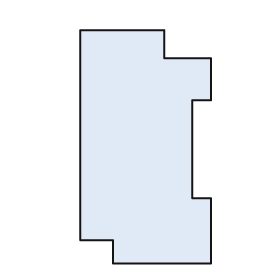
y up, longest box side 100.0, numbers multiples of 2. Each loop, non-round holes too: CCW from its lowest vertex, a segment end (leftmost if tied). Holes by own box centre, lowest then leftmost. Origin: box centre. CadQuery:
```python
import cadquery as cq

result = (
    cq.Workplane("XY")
    .moveTo(-14.0, -50.0)
    .lineTo(28.0, -50.0)
    .lineTo(28.0, -22.0)
    .lineTo(20.0, -22.0)
    .lineTo(20.0, 20.0)
    .lineTo(28.0, 20.0)
    .lineTo(28.0, 38.0)
    .lineTo(8.0, 38.0)
    .lineTo(8.0, 50.0)
    .lineTo(-28.0, 50.0)
    .lineTo(-28.0, -40.0)
    .lineTo(-14.0, -40.0)
    .close()
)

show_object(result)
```